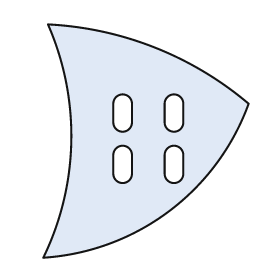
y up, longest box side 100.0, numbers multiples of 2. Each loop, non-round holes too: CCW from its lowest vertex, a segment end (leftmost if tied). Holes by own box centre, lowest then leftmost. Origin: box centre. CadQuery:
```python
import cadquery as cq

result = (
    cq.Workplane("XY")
    .moveTo(-44.0, -50.0)
    .threePointArc((10.0, -30.0), (44.0, 16.0))
    .threePointArc((4.0, 40.0), (-42.0, 50.0))
    .threePointArc((-32.0, 0.0), (-44.0, -50.0))
    .close()
    .moveTo(-14.0, -14.0)
    .threePointArc((-10.0, -18.0), (-6.0, -14.0))
    .lineTo(-6.0, -6.0)
    .threePointArc((-10.0, -2.0), (-14.0, -6.0))
    .close()
    .moveTo(8.0, -14.0)
    .threePointArc((12.0, -18.0), (16.0, -14.0))
    .lineTo(16.0, -6.0)
    .threePointArc((12.0, -2.0), (8.0, -6.0))
    .close()
    .moveTo(-14.0, 8.0)
    .threePointArc((-10.0, 4.0), (-6.0, 8.0))
    .lineTo(-6.0, 16.0)
    .threePointArc((-10.0, 20.0), (-14.0, 16.0))
    .close()
    .moveTo(8.0, 8.0)
    .threePointArc((12.0, 4.0), (16.0, 8.0))
    .lineTo(16.0, 16.0)
    .threePointArc((12.0, 20.0), (8.0, 16.0))
    .close()
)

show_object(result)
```